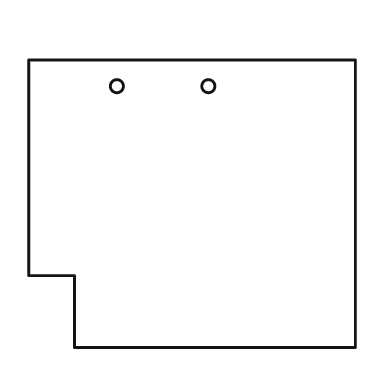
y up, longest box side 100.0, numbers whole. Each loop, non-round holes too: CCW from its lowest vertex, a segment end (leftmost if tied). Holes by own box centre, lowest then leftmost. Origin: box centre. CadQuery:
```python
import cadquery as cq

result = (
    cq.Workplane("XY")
    .moveTo(-36.0, -44.0)
    .lineTo(50.0, -44.0)
    .lineTo(50.0, 44.0)
    .lineTo(-50.0, 44.0)
    .lineTo(-50.0, -22.0)
    .lineTo(-36.0, -22.0)
    .close()
    .moveTo(-23.0, 36.0)
    .circle(2.0)
    .moveTo(5.0, 36.0)
    .circle(2.0)
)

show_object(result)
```